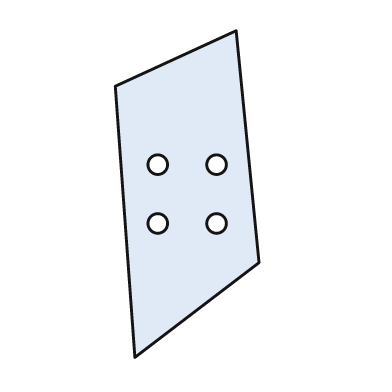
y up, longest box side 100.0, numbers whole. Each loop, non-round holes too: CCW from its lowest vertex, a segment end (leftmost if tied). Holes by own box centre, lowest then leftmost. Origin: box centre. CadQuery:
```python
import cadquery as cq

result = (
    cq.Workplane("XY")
    .moveTo(-16.0, -50.0)
    .lineTo(22.0, -21.0)
    .lineTo(15.0, 50.0)
    .lineTo(-22.0, 33.0)
    .close()
    .moveTo(-9.0, -9.0)
    .circle(3.0)
    .moveTo(9.0, -9.0)
    .circle(3.0)
    .moveTo(-9.0, 9.0)
    .circle(3.0)
    .moveTo(9.0, 9.0)
    .circle(3.0)
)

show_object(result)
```